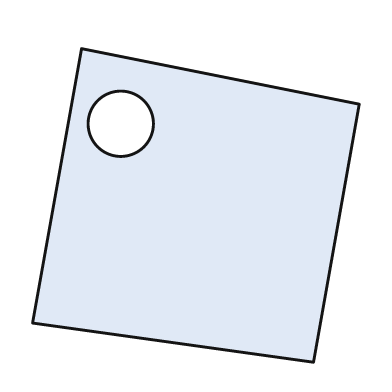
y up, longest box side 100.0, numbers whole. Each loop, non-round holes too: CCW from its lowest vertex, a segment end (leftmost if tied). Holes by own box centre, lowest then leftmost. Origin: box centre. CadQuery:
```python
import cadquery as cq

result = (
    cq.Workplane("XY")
    .moveTo(36.0, -48.0)
    .lineTo(50.0, 31.0)
    .lineTo(-35.0, 48.0)
    .lineTo(-50.0, -36.0)
    .close()
    .moveTo(-23.0, 25.0)
    .circle(10.0)
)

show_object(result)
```